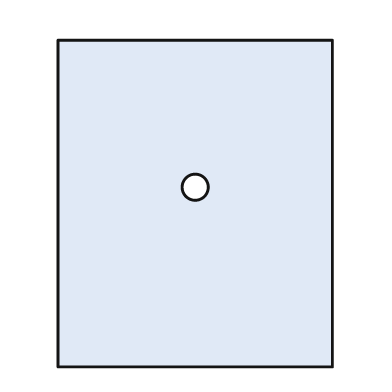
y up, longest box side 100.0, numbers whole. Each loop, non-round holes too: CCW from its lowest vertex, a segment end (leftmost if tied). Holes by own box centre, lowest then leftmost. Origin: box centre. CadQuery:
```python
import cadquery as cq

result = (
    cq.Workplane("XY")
    .moveTo(-42.0, -50.0)
    .lineTo(42.0, -50.0)
    .lineTo(42.0, 50.0)
    .lineTo(-42.0, 50.0)
    .close()
    .moveTo(0.0, 5.0)
    .circle(4.0)
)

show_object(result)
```